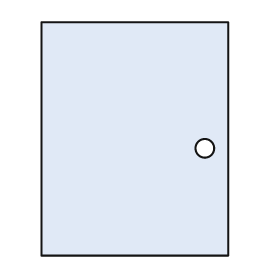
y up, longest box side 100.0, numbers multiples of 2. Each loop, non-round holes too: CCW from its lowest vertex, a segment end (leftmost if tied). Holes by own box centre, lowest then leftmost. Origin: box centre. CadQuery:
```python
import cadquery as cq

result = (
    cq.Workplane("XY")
    .moveTo(-40.0, -50.0)
    .lineTo(40.0, -50.0)
    .lineTo(40.0, 50.0)
    .lineTo(-40.0, 50.0)
    .close()
    .moveTo(30.0, -4.0)
    .circle(4.0)
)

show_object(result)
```